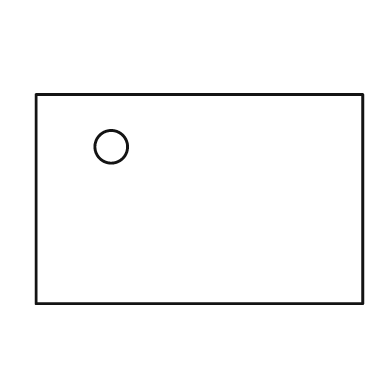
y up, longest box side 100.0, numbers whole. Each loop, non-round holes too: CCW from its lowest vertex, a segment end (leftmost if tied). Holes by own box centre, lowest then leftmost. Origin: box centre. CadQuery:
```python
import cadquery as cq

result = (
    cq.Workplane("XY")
    .moveTo(-50.0, -32.0)
    .lineTo(50.0, -32.0)
    .lineTo(50.0, 32.0)
    .lineTo(-50.0, 32.0)
    .close()
    .moveTo(-27.0, 16.0)
    .circle(5.0)
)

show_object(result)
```